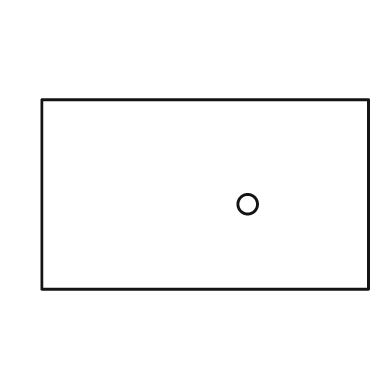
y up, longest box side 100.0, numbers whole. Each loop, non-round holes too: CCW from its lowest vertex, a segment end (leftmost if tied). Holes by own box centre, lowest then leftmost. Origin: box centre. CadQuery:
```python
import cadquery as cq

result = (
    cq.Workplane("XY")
    .moveTo(-50.0, -29.0)
    .lineTo(50.0, -29.0)
    .lineTo(50.0, 29.0)
    .lineTo(-50.0, 29.0)
    .close()
    .moveTo(13.0, -3.0)
    .circle(3.0)
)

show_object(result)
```